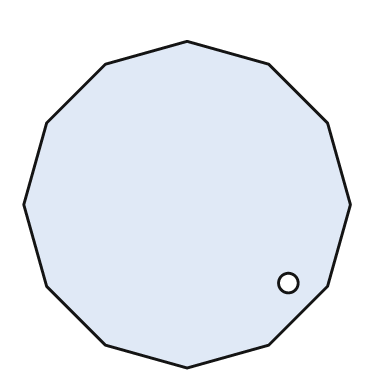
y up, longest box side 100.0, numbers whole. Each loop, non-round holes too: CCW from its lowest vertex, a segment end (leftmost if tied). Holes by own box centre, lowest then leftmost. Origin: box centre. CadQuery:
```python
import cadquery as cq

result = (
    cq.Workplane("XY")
    .moveTo(0.0, -50.0)
    .lineTo(25.0, -43.0)
    .lineTo(43.0, -25.0)
    .lineTo(50.0, 0.0)
    .lineTo(43.0, 25.0)
    .lineTo(25.0, 43.0)
    .lineTo(0.0, 50.0)
    .lineTo(-25.0, 43.0)
    .lineTo(-43.0, 25.0)
    .lineTo(-50.0, 0.0)
    .lineTo(-43.0, -25.0)
    .lineTo(-25.0, -43.0)
    .close()
    .moveTo(31.0, -24.0)
    .circle(3.0)
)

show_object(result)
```